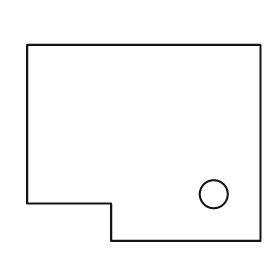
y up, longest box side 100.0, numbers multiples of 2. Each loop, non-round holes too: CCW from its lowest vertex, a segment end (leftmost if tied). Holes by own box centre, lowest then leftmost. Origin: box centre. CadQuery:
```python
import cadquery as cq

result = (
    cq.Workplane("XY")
    .moveTo(-14.0, -42.0)
    .lineTo(50.0, -42.0)
    .lineTo(50.0, 42.0)
    .lineTo(-50.0, 42.0)
    .lineTo(-50.0, -26.0)
    .lineTo(-14.0, -26.0)
    .close()
    .moveTo(30.0, -22.0)
    .circle(6.0)
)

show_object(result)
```